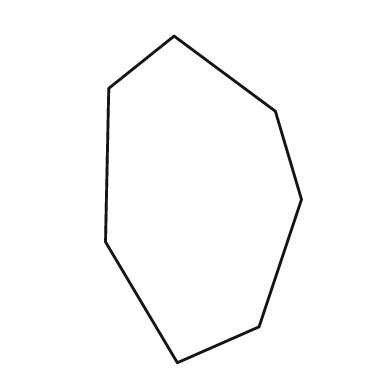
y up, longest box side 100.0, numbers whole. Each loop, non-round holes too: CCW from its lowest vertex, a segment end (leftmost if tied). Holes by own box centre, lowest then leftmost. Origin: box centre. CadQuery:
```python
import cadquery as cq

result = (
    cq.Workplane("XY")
    .moveTo(-8.0, -50.0)
    .lineTo(17.0, -39.0)
    .lineTo(30.0, 0.0)
    .lineTo(22.0, 27.0)
    .lineTo(-9.0, 50.0)
    .lineTo(-29.0, 34.0)
    .lineTo(-30.0, -13.0)
    .close()
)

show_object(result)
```